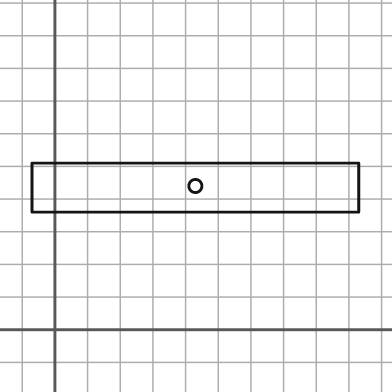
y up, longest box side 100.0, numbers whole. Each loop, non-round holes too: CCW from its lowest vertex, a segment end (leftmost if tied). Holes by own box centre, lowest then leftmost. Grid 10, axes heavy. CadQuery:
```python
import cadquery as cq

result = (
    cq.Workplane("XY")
    .moveTo(-7.0, 36.0)
    .lineTo(93.0, 36.0)
    .lineTo(93.0, 51.0)
    .lineTo(-7.0, 51.0)
    .close()
    .moveTo(43.0, 44.0)
    .circle(2.0)
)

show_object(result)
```